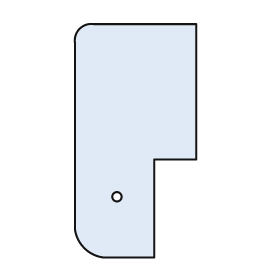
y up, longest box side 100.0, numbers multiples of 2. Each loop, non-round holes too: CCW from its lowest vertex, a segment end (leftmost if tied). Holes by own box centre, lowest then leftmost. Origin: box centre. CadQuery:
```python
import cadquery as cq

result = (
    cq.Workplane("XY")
    .moveTo(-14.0, -50.0)
    .lineTo(8.0, -50.0)
    .lineTo(8.0, -8.0)
    .lineTo(26.0, -8.0)
    .lineTo(26.0, 50.0)
    .lineTo(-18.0, 50.0)
    .threePointArc((-24.0, 48.0), (-26.0, 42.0))
    .lineTo(-26.0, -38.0)
    .threePointArc((-22.0, -46.0), (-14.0, -50.0))
    .close()
    .moveTo(-8.0, -24.0)
    .circle(2.0)
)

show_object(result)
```